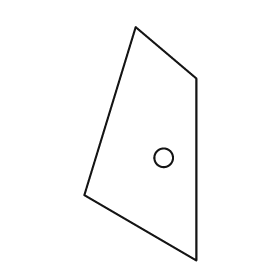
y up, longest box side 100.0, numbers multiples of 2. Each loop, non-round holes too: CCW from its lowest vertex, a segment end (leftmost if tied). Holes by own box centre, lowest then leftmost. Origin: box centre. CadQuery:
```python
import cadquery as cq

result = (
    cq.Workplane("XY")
    .moveTo(24.0, -50.0)
    .lineTo(24.0, 28.0)
    .lineTo(-2.0, 50.0)
    .lineTo(-24.0, -22.0)
    .close()
    .moveTo(10.0, -6.0)
    .circle(4.0)
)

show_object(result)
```